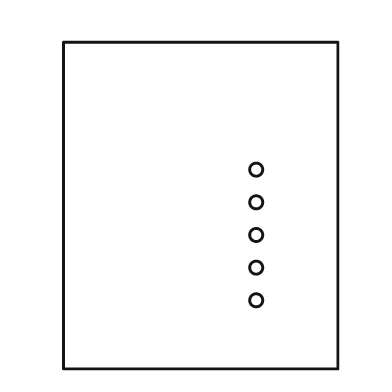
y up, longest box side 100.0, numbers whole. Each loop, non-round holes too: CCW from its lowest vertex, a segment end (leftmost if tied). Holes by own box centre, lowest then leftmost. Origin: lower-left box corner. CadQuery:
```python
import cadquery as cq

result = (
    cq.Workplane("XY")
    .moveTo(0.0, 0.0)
    .lineTo(84.0, 0.0)
    .lineTo(84.0, 100.0)
    .lineTo(0.0, 100.0)
    .close()
    .moveTo(59.0, 21.0)
    .circle(2.0)
    .moveTo(59.0, 31.0)
    .circle(2.0)
    .moveTo(59.0, 41.0)
    .circle(2.0)
    .moveTo(59.0, 51.0)
    .circle(2.0)
    .moveTo(59.0, 61.0)
    .circle(2.0)
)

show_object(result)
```